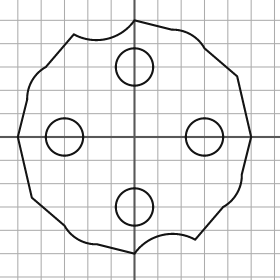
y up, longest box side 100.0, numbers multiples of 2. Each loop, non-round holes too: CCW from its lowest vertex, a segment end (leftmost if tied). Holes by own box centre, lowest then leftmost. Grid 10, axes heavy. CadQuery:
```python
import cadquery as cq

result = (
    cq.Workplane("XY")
    .moveTo(0.0, -50.0)
    .threePointArc((12.0, -42.0), (26.0, -44.0))
    .lineTo(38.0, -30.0)
    .threePointArc((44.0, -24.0), (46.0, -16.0))
    .lineTo(50.0, 0.0)
    .lineTo(44.0, 26.0)
    .lineTo(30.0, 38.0)
    .threePointArc((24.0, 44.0), (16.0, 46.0))
    .lineTo(0.0, 50.0)
    .threePointArc((-12.0, 42.0), (-26.0, 44.0))
    .lineTo(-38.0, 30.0)
    .threePointArc((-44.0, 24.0), (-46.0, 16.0))
    .lineTo(-50.0, 0.0)
    .lineTo(-44.0, -26.0)
    .lineTo(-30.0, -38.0)
    .threePointArc((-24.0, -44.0), (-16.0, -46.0))
    .close()
    .moveTo(0.0, -30.0)
    .circle(8.0)
    .moveTo(-30.0, 0.0)
    .circle(8.0)
    .moveTo(30.0, 0.0)
    .circle(8.0)
    .moveTo(0.0, 30.0)
    .circle(8.0)
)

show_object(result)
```